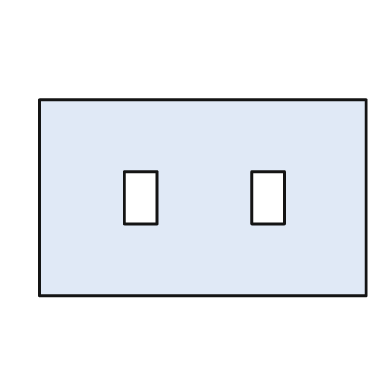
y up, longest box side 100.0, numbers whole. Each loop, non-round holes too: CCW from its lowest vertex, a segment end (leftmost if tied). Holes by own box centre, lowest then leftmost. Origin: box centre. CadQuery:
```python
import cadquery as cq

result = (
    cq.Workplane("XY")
    .moveTo(-50.0, -30.0)
    .lineTo(50.0, -30.0)
    .lineTo(50.0, 30.0)
    .lineTo(-50.0, 30.0)
    .close()
    .moveTo(-24.0, -8.0)
    .lineTo(-14.0, -8.0)
    .lineTo(-14.0, 8.0)
    .lineTo(-24.0, 8.0)
    .close()
    .moveTo(15.0, -8.0)
    .lineTo(25.0, -8.0)
    .lineTo(25.0, 8.0)
    .lineTo(15.0, 8.0)
    .close()
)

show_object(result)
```